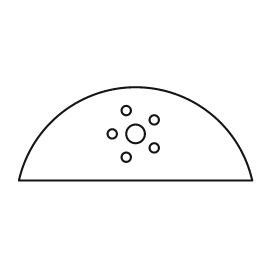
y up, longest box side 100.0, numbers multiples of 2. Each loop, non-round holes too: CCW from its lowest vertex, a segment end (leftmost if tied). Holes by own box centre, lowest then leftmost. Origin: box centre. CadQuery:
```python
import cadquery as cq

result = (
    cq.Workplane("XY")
    .moveTo(-50.0, -20.0)
    .lineTo(50.0, -20.0)
    .threePointArc((0.0, 20.0), (-50.0, -20.0))
    .close()
    .moveTo(-4.0, -10.0)
    .circle(2.0)
    .moveTo(8.0, -6.0)
    .circle(2.0)
    .moveTo(-10.0, 0.0)
    .circle(2.0)
    .moveTo(0.0, 0.0)
    .circle(4.0)
    .moveTo(8.0, 6.0)
    .circle(2.0)
    .moveTo(-4.0, 10.0)
    .circle(2.0)
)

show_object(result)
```